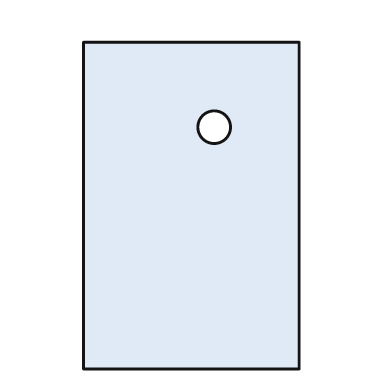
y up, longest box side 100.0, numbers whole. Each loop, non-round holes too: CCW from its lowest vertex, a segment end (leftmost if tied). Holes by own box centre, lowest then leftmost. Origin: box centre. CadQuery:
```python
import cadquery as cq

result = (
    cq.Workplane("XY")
    .moveTo(-33.0, -50.0)
    .lineTo(33.0, -50.0)
    .lineTo(33.0, 50.0)
    .lineTo(-33.0, 50.0)
    .close()
    .moveTo(7.0, 24.0)
    .circle(5.0)
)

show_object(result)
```